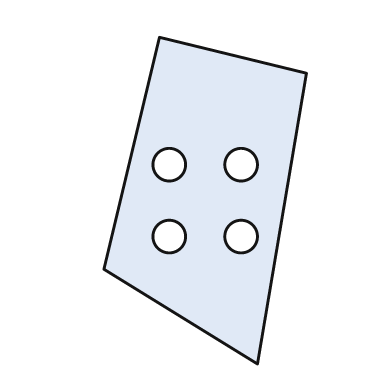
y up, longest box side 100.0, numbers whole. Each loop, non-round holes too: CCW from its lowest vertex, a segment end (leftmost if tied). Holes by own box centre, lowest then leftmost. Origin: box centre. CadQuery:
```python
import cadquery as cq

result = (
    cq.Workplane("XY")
    .moveTo(16.0, -50.0)
    .lineTo(31.0, 39.0)
    .lineTo(-14.0, 50.0)
    .lineTo(-31.0, -21.0)
    .close()
    .moveTo(-11.0, -11.0)
    .circle(5.0)
    .moveTo(11.0, -11.0)
    .circle(5.0)
    .moveTo(-11.0, 11.0)
    .circle(5.0)
    .moveTo(11.0, 11.0)
    .circle(5.0)
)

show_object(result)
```